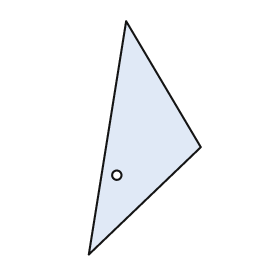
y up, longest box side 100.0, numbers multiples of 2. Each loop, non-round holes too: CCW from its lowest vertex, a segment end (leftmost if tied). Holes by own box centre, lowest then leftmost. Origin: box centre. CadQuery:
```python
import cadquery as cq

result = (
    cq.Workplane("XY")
    .moveTo(-24.0, -50.0)
    .lineTo(24.0, -4.0)
    .lineTo(-8.0, 50.0)
    .close()
    .moveTo(-12.0, -16.0)
    .circle(2.0)
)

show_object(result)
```